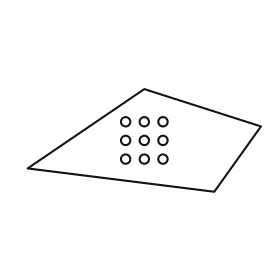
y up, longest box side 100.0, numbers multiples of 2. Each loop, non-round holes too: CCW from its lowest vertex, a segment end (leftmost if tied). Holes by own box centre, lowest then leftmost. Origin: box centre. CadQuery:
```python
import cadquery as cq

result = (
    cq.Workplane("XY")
    .moveTo(30.0, -22.0)
    .lineTo(50.0, 6.0)
    .lineTo(0.0, 22.0)
    .lineTo(-50.0, -12.0)
    .close()
    .moveTo(-8.0, -8.0)
    .circle(2.0)
    .moveTo(0.0, -8.0)
    .circle(2.0)
    .moveTo(8.0, -8.0)
    .circle(2.0)
    .moveTo(-8.0, 0.0)
    .circle(2.0)
    .moveTo(0.0, 0.0)
    .circle(2.0)
    .moveTo(8.0, 0.0)
    .circle(2.0)
    .moveTo(-8.0, 8.0)
    .circle(2.0)
    .moveTo(0.0, 8.0)
    .circle(2.0)
    .moveTo(8.0, 8.0)
    .circle(2.0)
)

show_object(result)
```